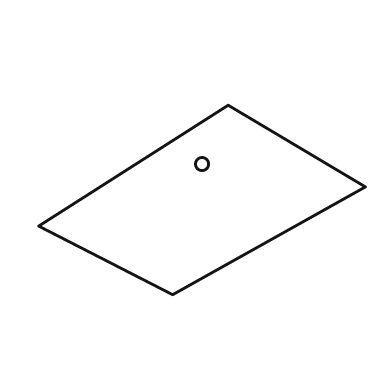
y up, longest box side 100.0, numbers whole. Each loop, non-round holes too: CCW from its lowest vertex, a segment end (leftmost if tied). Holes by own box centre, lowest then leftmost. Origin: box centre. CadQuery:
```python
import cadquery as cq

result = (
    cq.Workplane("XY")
    .moveTo(-9.0, -29.0)
    .lineTo(50.0, 4.0)
    .lineTo(8.0, 29.0)
    .lineTo(-50.0, -8.0)
    .close()
    .moveTo(0.0, 11.0)
    .circle(2.0)
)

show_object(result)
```